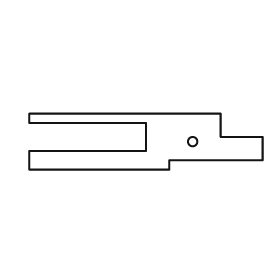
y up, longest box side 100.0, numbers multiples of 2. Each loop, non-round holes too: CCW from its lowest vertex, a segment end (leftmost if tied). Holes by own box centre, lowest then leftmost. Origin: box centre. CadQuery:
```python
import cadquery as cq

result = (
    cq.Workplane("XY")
    .moveTo(-50.0, -12.0)
    .lineTo(10.0, -12.0)
    .lineTo(10.0, -8.0)
    .lineTo(50.0, -8.0)
    .lineTo(50.0, 2.0)
    .lineTo(32.0, 2.0)
    .lineTo(32.0, 12.0)
    .lineTo(-50.0, 12.0)
    .lineTo(-50.0, 8.0)
    .lineTo(0.0, 8.0)
    .lineTo(0.0, -4.0)
    .lineTo(-50.0, -4.0)
    .close()
    .moveTo(20.0, 0.0)
    .circle(2.0)
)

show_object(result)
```